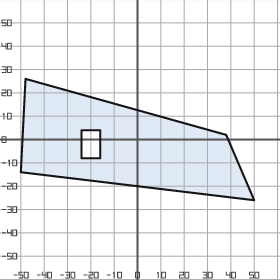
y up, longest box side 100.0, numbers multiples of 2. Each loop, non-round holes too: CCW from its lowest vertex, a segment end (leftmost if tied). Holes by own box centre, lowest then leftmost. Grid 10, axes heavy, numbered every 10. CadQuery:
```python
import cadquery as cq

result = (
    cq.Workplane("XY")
    .moveTo(50.0, -26.0)
    .lineTo(38.0, 2.0)
    .lineTo(-48.0, 26.0)
    .lineTo(-50.0, -14.0)
    .close()
    .moveTo(-24.0, -8.0)
    .lineTo(-16.0, -8.0)
    .lineTo(-16.0, 4.0)
    .lineTo(-24.0, 4.0)
    .close()
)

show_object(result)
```